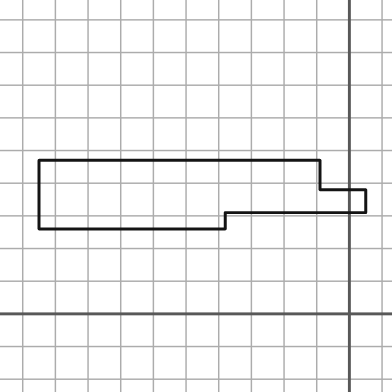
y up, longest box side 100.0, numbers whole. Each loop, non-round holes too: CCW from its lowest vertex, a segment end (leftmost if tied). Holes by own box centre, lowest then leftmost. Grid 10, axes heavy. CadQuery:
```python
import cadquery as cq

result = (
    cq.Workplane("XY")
    .moveTo(-95.0, 26.0)
    .lineTo(-38.0, 26.0)
    .lineTo(-38.0, 31.0)
    .lineTo(5.0, 31.0)
    .lineTo(5.0, 38.0)
    .lineTo(-9.0, 38.0)
    .lineTo(-9.0, 47.0)
    .lineTo(-95.0, 47.0)
    .close()
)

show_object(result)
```